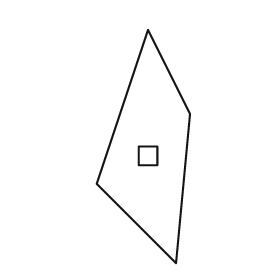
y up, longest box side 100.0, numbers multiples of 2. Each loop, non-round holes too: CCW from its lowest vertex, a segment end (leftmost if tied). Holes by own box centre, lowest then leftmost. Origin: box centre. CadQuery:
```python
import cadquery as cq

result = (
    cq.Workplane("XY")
    .moveTo(14.0, -50.0)
    .lineTo(20.0, 14.0)
    .lineTo(2.0, 50.0)
    .lineTo(-20.0, -16.0)
    .close()
    .moveTo(-2.0, -8.0)
    .lineTo(6.0, -8.0)
    .lineTo(6.0, 0.0)
    .lineTo(-2.0, 0.0)
    .close()
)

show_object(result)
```